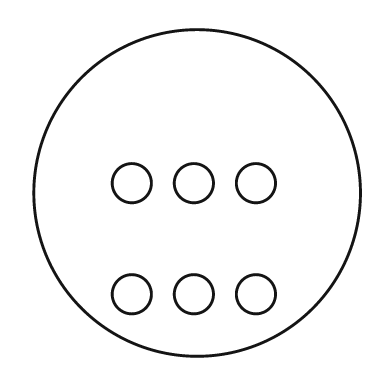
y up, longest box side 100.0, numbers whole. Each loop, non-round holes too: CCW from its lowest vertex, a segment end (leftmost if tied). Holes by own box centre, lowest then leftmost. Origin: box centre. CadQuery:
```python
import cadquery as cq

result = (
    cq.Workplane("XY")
    .moveTo(0.0, 0.0)
    .circle(50.0)
    .moveTo(-20.0, -31.0)
    .circle(6.0)
    .moveTo(-1.0, -31.0)
    .circle(6.0)
    .moveTo(18.0, -31.0)
    .circle(6.0)
    .moveTo(-20.0, 3.0)
    .circle(6.0)
    .moveTo(-1.0, 3.0)
    .circle(6.0)
    .moveTo(18.0, 3.0)
    .circle(6.0)
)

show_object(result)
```